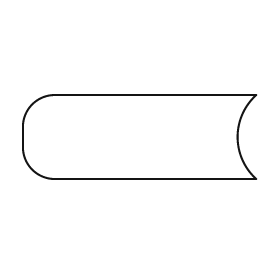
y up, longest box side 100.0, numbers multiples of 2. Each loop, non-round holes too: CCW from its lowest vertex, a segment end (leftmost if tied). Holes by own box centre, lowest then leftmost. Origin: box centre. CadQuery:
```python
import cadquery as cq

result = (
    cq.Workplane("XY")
    .moveTo(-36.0, -18.0)
    .lineTo(50.0, -18.0)
    .threePointArc((42.0, 0.0), (50.0, 18.0))
    .lineTo(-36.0, 18.0)
    .threePointArc((-46.0, 14.0), (-50.0, 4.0))
    .lineTo(-50.0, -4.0)
    .threePointArc((-46.0, -14.0), (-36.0, -18.0))
    .close()
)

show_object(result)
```